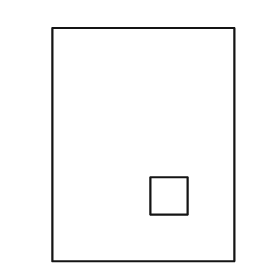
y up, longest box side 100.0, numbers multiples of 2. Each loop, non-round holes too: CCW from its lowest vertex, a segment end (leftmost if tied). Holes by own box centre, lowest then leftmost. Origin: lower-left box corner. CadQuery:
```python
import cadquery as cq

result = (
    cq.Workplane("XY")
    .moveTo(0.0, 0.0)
    .lineTo(78.0, 0.0)
    .lineTo(78.0, 100.0)
    .lineTo(0.0, 100.0)
    .close()
    .moveTo(42.0, 20.0)
    .lineTo(58.0, 20.0)
    .lineTo(58.0, 36.0)
    .lineTo(42.0, 36.0)
    .close()
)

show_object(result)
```